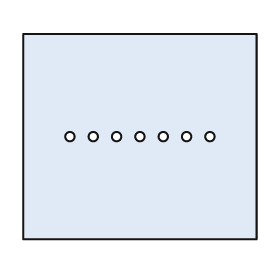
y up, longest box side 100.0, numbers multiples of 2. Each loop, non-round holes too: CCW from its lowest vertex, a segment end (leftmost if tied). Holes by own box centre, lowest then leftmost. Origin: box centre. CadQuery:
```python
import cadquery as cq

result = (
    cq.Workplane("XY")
    .moveTo(-50.0, -44.0)
    .lineTo(50.0, -44.0)
    .lineTo(50.0, 44.0)
    .lineTo(-50.0, 44.0)
    .close()
    .moveTo(-30.0, 0.0)
    .circle(2.0)
    .moveTo(-20.0, 0.0)
    .circle(2.0)
    .moveTo(-10.0, 0.0)
    .circle(2.0)
    .moveTo(0.0, 0.0)
    .circle(2.0)
    .moveTo(10.0, 0.0)
    .circle(2.0)
    .moveTo(20.0, 0.0)
    .circle(2.0)
    .moveTo(30.0, 0.0)
    .circle(2.0)
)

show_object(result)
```